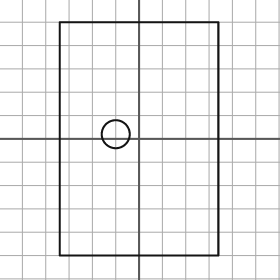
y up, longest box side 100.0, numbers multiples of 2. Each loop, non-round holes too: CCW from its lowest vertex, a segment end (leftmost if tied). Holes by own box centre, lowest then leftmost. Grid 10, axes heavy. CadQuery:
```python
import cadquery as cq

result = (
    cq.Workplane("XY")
    .moveTo(-34.0, -50.0)
    .lineTo(34.0, -50.0)
    .lineTo(34.0, 50.0)
    .lineTo(-34.0, 50.0)
    .close()
    .moveTo(-10.0, 2.0)
    .circle(6.0)
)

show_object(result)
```